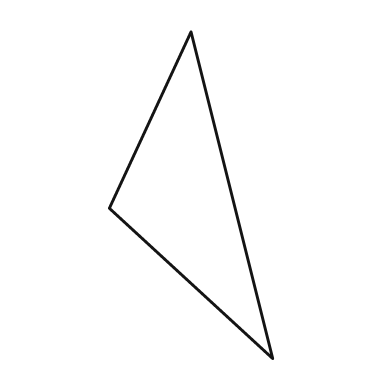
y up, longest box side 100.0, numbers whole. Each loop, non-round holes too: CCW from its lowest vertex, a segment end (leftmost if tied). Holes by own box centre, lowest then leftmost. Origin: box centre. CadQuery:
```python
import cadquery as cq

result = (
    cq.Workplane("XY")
    .moveTo(25.0, -50.0)
    .lineTo(0.0, 50.0)
    .lineTo(-25.0, -4.0)
    .close()
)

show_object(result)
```